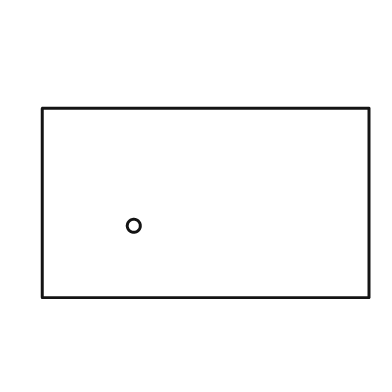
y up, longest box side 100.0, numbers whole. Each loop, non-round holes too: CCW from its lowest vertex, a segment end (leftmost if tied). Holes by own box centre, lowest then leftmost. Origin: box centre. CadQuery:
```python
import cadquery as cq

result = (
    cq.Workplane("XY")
    .moveTo(-50.0, -29.0)
    .lineTo(50.0, -29.0)
    .lineTo(50.0, 29.0)
    .lineTo(-50.0, 29.0)
    .close()
    .moveTo(-22.0, -7.0)
    .circle(2.0)
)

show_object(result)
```